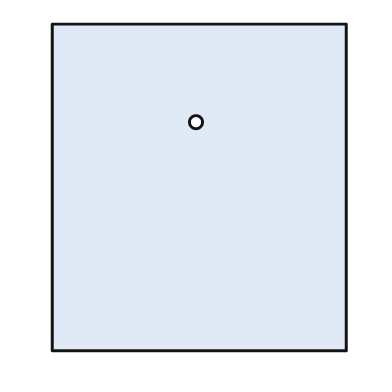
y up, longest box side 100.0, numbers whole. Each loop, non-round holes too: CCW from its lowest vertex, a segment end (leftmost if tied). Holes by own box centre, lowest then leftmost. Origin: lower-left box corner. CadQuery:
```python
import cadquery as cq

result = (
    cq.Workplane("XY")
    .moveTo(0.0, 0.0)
    .lineTo(90.0, 0.0)
    .lineTo(90.0, 100.0)
    .lineTo(0.0, 100.0)
    .close()
    .moveTo(44.0, 70.0)
    .circle(2.0)
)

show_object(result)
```